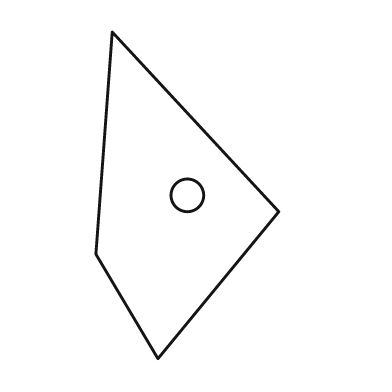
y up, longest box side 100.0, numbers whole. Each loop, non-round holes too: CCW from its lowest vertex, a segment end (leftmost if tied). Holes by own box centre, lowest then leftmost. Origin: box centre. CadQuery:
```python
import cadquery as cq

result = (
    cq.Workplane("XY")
    .moveTo(-9.0, -50.0)
    .lineTo(28.0, -5.0)
    .lineTo(-23.0, 50.0)
    .lineTo(-28.0, -18.0)
    .close()
    .moveTo(0.0, 0.0)
    .circle(5.0)
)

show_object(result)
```